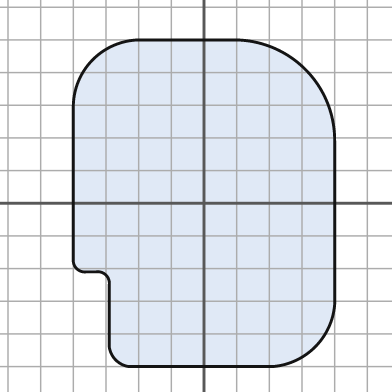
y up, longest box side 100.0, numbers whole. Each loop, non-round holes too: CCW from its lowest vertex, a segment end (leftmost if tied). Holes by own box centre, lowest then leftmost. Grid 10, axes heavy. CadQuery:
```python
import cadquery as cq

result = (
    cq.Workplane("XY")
    .moveTo(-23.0, -50.0)
    .lineTo(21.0, -50.0)
    .threePointArc((34.0, -44.0), (40.0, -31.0))
    .lineTo(40.0, 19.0)
    .threePointArc((31.0, 41.0), (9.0, 50.0))
    .lineTo(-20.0, 50.0)
    .threePointArc((-34.0, 44.0), (-40.0, 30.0))
    .lineTo(-40.0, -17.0)
    .threePointArc((-39.0, -20.0), (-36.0, -21.0))
    .lineTo(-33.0, -21.0)
    .threePointArc((-30.0, -22.0), (-29.0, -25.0))
    .lineTo(-29.0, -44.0)
    .threePointArc((-27.0, -48.0), (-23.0, -50.0))
    .close()
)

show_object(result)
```